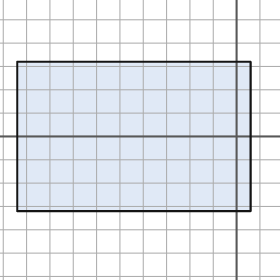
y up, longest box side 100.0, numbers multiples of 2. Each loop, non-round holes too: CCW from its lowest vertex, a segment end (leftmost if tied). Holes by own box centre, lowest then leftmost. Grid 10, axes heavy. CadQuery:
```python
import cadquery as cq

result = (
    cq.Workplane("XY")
    .moveTo(-94.0, -32.0)
    .lineTo(6.0, -32.0)
    .lineTo(6.0, 32.0)
    .lineTo(-94.0, 32.0)
    .close()
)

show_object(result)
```